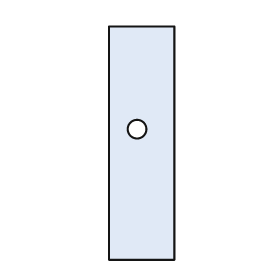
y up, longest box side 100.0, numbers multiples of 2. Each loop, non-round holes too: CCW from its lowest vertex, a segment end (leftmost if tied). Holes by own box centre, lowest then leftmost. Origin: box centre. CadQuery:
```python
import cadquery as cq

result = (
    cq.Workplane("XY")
    .moveTo(-14.0, -50.0)
    .lineTo(14.0, -50.0)
    .lineTo(14.0, 50.0)
    .lineTo(-14.0, 50.0)
    .close()
    .moveTo(-2.0, 6.0)
    .circle(4.0)
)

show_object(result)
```